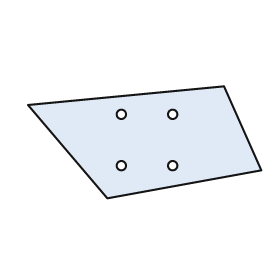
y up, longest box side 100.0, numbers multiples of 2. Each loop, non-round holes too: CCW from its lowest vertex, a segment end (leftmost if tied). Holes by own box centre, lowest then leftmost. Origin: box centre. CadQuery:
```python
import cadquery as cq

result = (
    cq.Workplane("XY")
    .moveTo(-16.0, -24.0)
    .lineTo(50.0, -12.0)
    .lineTo(34.0, 24.0)
    .lineTo(-50.0, 16.0)
    .close()
    .moveTo(-10.0, -10.0)
    .circle(2.0)
    .moveTo(12.0, -10.0)
    .circle(2.0)
    .moveTo(-10.0, 12.0)
    .circle(2.0)
    .moveTo(12.0, 12.0)
    .circle(2.0)
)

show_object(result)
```